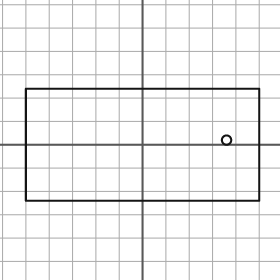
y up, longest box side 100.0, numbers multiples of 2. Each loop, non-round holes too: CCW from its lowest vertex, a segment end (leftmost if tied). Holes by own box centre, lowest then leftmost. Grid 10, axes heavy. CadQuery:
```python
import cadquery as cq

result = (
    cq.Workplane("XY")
    .moveTo(-50.0, -24.0)
    .lineTo(50.0, -24.0)
    .lineTo(50.0, 24.0)
    .lineTo(-50.0, 24.0)
    .close()
    .moveTo(36.0, 2.0)
    .circle(2.0)
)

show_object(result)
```